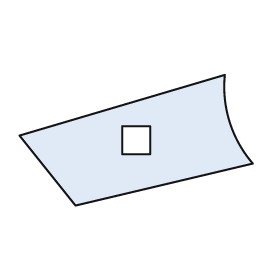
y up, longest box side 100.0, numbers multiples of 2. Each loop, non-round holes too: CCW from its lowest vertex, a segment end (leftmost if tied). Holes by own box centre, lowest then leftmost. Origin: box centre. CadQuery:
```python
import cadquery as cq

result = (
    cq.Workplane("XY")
    .moveTo(-26.0, -28.0)
    .lineTo(50.0, -10.0)
    .threePointArc((40.0, 8.0), (38.0, 28.0))
    .lineTo(-50.0, 2.0)
    .close()
    .moveTo(-6.0, -6.0)
    .lineTo(6.0, -6.0)
    .lineTo(6.0, 6.0)
    .lineTo(-6.0, 6.0)
    .close()
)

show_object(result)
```